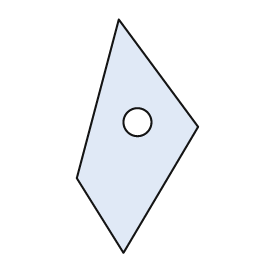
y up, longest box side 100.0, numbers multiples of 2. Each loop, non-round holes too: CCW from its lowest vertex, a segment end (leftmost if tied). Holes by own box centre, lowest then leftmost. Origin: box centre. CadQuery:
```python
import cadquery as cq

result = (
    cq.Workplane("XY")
    .moveTo(-6.0, -50.0)
    .lineTo(26.0, 4.0)
    .lineTo(-8.0, 50.0)
    .lineTo(-26.0, -18.0)
    .close()
    .moveTo(0.0, 6.0)
    .circle(6.0)
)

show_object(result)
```